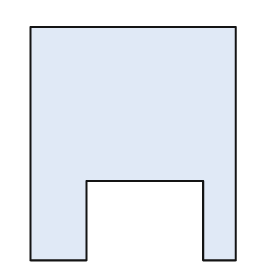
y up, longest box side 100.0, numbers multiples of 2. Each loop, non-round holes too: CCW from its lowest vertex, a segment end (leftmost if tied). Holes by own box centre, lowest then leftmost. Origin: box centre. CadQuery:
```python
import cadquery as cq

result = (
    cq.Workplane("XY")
    .moveTo(-44.0, -50.0)
    .lineTo(-20.0, -50.0)
    .lineTo(-20.0, -16.0)
    .lineTo(30.0, -16.0)
    .lineTo(30.0, -50.0)
    .lineTo(44.0, -50.0)
    .lineTo(44.0, 50.0)
    .lineTo(-44.0, 50.0)
    .close()
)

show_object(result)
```